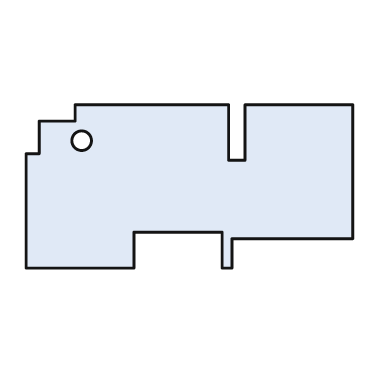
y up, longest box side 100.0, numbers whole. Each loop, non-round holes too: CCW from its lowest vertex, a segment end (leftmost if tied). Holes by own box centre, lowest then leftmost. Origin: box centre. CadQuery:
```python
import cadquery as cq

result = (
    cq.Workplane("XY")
    .moveTo(-50.0, -25.0)
    .lineTo(-17.0, -25.0)
    .lineTo(-17.0, -14.0)
    .lineTo(10.0, -14.0)
    .lineTo(10.0, -25.0)
    .lineTo(13.0, -25.0)
    .lineTo(13.0, -16.0)
    .lineTo(50.0, -16.0)
    .lineTo(50.0, 25.0)
    .lineTo(17.0, 25.0)
    .lineTo(17.0, 8.0)
    .lineTo(12.0, 8.0)
    .lineTo(12.0, 25.0)
    .lineTo(-35.0, 25.0)
    .lineTo(-35.0, 20.0)
    .lineTo(-46.0, 20.0)
    .lineTo(-46.0, 10.0)
    .lineTo(-50.0, 10.0)
    .close()
    .moveTo(-33.0, 14.0)
    .circle(3.0)
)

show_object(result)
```